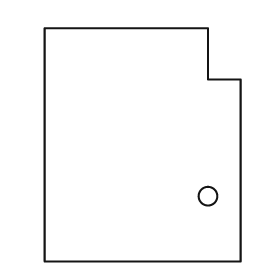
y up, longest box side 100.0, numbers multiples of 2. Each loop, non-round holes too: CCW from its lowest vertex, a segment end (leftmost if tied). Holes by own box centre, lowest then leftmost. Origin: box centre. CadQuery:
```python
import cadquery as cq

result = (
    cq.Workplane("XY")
    .moveTo(-42.0, -50.0)
    .lineTo(42.0, -50.0)
    .lineTo(42.0, 28.0)
    .lineTo(28.0, 28.0)
    .lineTo(28.0, 50.0)
    .lineTo(-42.0, 50.0)
    .close()
    .moveTo(28.0, -22.0)
    .circle(4.0)
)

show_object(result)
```